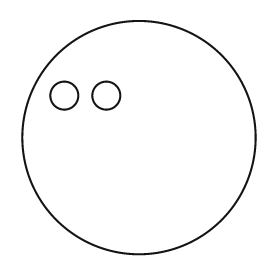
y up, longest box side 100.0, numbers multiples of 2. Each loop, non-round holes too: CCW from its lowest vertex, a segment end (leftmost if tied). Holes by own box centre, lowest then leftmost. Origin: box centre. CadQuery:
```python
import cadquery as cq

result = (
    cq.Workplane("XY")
    .moveTo(0.0, 0.0)
    .circle(50.0)
    .moveTo(-32.0, 18.0)
    .circle(6.0)
    .moveTo(-14.0, 18.0)
    .circle(6.0)
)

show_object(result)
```